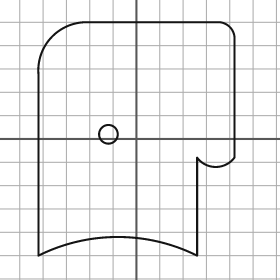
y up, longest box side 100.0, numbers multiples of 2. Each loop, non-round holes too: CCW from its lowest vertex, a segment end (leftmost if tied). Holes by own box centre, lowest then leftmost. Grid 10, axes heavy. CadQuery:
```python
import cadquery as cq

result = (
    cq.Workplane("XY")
    .moveTo(-42.0, -50.0)
    .threePointArc((-8.0, -42.0), (26.0, -50.0))
    .lineTo(26.0, -8.0)
    .threePointArc((34.0, -12.0), (42.0, -8.0))
    .lineTo(42.0, 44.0)
    .threePointArc((40.0, 48.0), (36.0, 50.0))
    .lineTo(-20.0, 50.0)
    .threePointArc((-36.0, 44.0), (-42.0, 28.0))
    .close()
    .moveTo(-12.0, 2.0)
    .circle(4.0)
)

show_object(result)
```